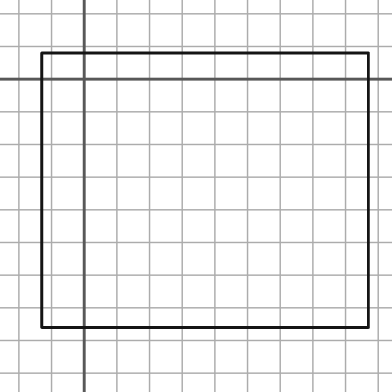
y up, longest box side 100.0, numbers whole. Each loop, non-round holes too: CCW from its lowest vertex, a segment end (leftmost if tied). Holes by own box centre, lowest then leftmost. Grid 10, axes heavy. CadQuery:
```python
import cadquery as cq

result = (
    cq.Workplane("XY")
    .moveTo(-13.0, -76.0)
    .lineTo(87.0, -76.0)
    .lineTo(87.0, 8.0)
    .lineTo(-13.0, 8.0)
    .close()
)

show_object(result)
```